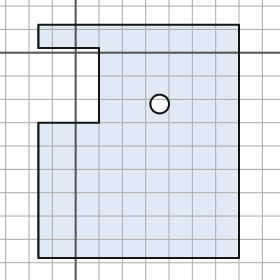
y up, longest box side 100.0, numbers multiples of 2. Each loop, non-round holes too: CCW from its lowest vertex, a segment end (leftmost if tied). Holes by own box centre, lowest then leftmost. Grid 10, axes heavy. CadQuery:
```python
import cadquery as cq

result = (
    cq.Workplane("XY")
    .moveTo(-16.0, -88.0)
    .lineTo(70.0, -88.0)
    .lineTo(70.0, 12.0)
    .lineTo(-16.0, 12.0)
    .lineTo(-16.0, 2.0)
    .lineTo(10.0, 2.0)
    .lineTo(10.0, -30.0)
    .lineTo(-16.0, -30.0)
    .close()
    .moveTo(36.0, -22.0)
    .circle(4.0)
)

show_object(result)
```